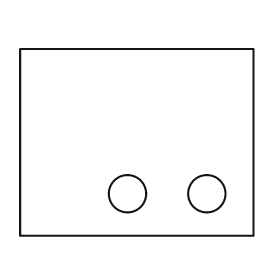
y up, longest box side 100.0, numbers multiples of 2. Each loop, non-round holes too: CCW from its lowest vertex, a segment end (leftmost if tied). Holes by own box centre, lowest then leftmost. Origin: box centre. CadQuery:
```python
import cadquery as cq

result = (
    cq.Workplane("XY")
    .moveTo(-50.0, -40.0)
    .lineTo(50.0, -40.0)
    .lineTo(50.0, 40.0)
    .lineTo(-50.0, 40.0)
    .close()
    .moveTo(-4.0, -22.0)
    .circle(8.0)
    .moveTo(30.0, -22.0)
    .circle(8.0)
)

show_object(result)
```